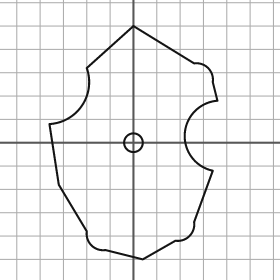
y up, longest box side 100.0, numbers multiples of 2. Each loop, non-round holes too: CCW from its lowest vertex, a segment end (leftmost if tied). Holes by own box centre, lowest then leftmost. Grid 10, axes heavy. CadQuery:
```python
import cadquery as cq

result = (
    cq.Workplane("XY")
    .moveTo(4.0, -50.0)
    .lineTo(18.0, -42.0)
    .threePointArc((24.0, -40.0), (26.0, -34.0))
    .lineTo(34.0, -12.0)
    .threePointArc((22.0, 4.0), (36.0, 18.0))
    .lineTo(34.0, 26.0)
    .threePointArc((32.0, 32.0), (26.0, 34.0))
    .lineTo(0.0, 50.0)
    .lineTo(-20.0, 32.0)
    .threePointArc((-22.0, 16.0), (-36.0, 8.0))
    .lineTo(-32.0, -18.0)
    .lineTo(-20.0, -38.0)
    .threePointArc((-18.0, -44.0), (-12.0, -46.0))
    .close()
    .moveTo(0.0, 0.0)
    .circle(4.0)
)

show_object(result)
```